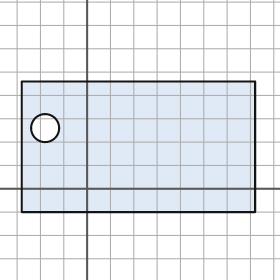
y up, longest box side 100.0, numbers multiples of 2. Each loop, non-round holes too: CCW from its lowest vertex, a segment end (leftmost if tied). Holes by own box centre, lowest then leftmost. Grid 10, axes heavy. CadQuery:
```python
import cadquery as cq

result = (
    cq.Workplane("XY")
    .moveTo(-28.0, -10.0)
    .lineTo(72.0, -10.0)
    .lineTo(72.0, 46.0)
    .lineTo(-28.0, 46.0)
    .close()
    .moveTo(-18.0, 26.0)
    .circle(6.0)
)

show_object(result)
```